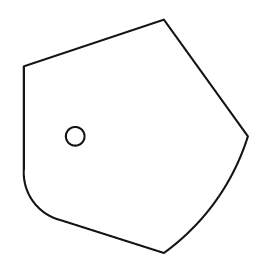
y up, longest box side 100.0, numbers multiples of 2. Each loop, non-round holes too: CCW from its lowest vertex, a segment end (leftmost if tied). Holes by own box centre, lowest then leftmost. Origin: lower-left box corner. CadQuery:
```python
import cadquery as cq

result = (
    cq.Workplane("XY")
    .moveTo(60.0, 0.0)
    .threePointArc((82.0, 22.0), (96.0, 50.0))
    .lineTo(60.0, 100.0)
    .lineTo(0.0, 80.0)
    .lineTo(0.0, 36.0)
    .threePointArc((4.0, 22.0), (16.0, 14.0))
    .close()
    .moveTo(22.0, 50.0)
    .circle(4.0)
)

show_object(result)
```